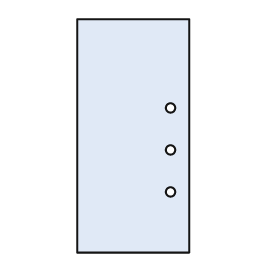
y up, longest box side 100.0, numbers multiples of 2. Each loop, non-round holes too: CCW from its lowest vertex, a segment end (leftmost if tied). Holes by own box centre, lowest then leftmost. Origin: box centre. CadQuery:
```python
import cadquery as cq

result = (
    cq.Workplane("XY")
    .moveTo(-24.0, -50.0)
    .lineTo(24.0, -50.0)
    .lineTo(24.0, 50.0)
    .lineTo(-24.0, 50.0)
    .close()
    .moveTo(16.0, -24.0)
    .circle(2.0)
    .moveTo(16.0, -6.0)
    .circle(2.0)
    .moveTo(16.0, 12.0)
    .circle(2.0)
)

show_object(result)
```